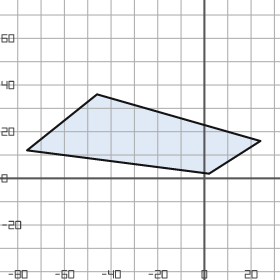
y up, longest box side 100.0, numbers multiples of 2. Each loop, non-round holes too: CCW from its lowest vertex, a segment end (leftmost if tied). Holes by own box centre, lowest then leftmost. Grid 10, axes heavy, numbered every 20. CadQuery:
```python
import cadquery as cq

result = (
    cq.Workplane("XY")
    .moveTo(2.0, 2.0)
    .lineTo(24.0, 16.0)
    .lineTo(-46.0, 36.0)
    .lineTo(-76.0, 12.0)
    .close()
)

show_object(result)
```